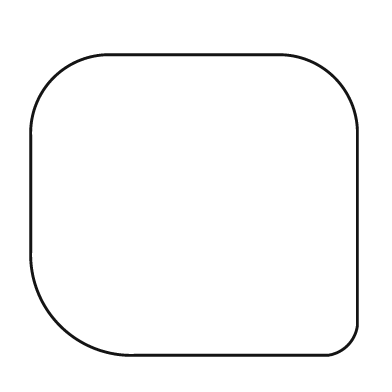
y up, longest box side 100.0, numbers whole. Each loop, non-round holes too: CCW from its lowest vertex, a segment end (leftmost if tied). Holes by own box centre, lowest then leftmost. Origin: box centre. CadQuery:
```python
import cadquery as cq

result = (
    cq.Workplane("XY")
    .moveTo(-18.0, -46.0)
    .lineTo(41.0, -46.0)
    .threePointArc((47.0, -43.0), (50.0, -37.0))
    .lineTo(50.0, 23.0)
    .threePointArc((43.0, 39.0), (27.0, 46.0))
    .lineTo(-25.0, 46.0)
    .threePointArc((-43.0, 39.0), (-50.0, 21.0))
    .lineTo(-50.0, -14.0)
    .threePointArc((-41.0, -37.0), (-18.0, -46.0))
    .close()
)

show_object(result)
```